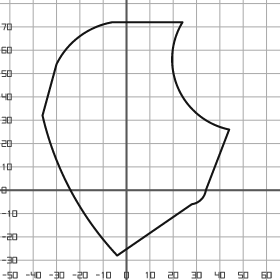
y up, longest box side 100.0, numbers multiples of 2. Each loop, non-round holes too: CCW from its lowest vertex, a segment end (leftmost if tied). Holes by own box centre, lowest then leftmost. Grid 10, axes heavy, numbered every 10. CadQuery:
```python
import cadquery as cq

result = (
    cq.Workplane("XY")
    .moveTo(-4.0, -28.0)
    .lineTo(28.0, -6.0)
    .threePointArc((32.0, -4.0), (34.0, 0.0))
    .lineTo(44.0, 26.0)
    .threePointArc((22.0, 44.0), (24.0, 72.0))
    .lineTo(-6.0, 72.0)
    .threePointArc((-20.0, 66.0), (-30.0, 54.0))
    .lineTo(-36.0, 32.0)
    .threePointArc((-24.0, 0.0), (-4.0, -28.0))
    .close()
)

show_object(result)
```